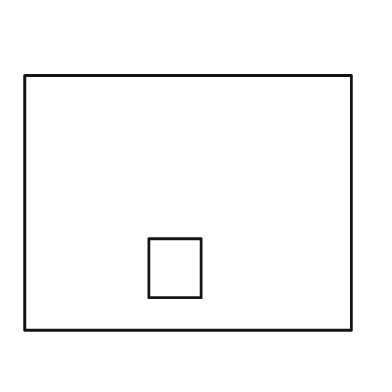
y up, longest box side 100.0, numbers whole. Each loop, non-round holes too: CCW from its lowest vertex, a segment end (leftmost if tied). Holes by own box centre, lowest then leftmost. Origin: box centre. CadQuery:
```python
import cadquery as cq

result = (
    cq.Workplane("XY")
    .moveTo(-50.0, -39.0)
    .lineTo(50.0, -39.0)
    .lineTo(50.0, 39.0)
    .lineTo(-50.0, 39.0)
    .close()
    .moveTo(-12.0, -29.0)
    .lineTo(4.0, -29.0)
    .lineTo(4.0, -11.0)
    .lineTo(-12.0, -11.0)
    .close()
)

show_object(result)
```